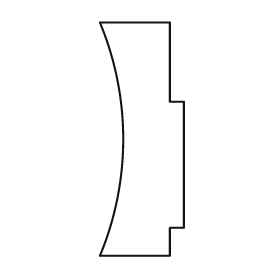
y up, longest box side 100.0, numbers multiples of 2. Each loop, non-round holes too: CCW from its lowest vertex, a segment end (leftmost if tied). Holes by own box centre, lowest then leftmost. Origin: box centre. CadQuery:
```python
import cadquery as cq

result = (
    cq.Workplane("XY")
    .moveTo(-18.0, -50.0)
    .lineTo(12.0, -50.0)
    .lineTo(12.0, -38.0)
    .lineTo(18.0, -38.0)
    .lineTo(18.0, 16.0)
    .lineTo(12.0, 16.0)
    .lineTo(12.0, 50.0)
    .lineTo(-18.0, 50.0)
    .threePointArc((-8.0, 0.0), (-18.0, -50.0))
    .close()
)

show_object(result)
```